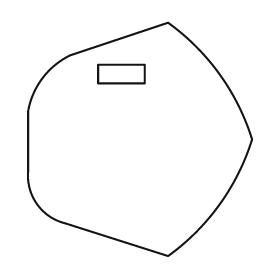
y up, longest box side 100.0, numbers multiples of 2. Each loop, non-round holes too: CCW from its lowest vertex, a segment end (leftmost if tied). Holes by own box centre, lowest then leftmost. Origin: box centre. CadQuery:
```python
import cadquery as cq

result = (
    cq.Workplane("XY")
    .moveTo(12.0, -50.0)
    .threePointArc((34.0, -28.0), (48.0, 0.0))
    .threePointArc((34.0, 28.0), (12.0, 50.0))
    .lineTo(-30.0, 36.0)
    .threePointArc((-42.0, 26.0), (-48.0, 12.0))
    .lineTo(-48.0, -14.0)
    .threePointArc((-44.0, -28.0), (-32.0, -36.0))
    .close()
    .moveTo(-18.0, 24.0)
    .lineTo(2.0, 24.0)
    .lineTo(2.0, 32.0)
    .lineTo(-18.0, 32.0)
    .close()
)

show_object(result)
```